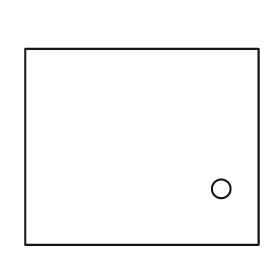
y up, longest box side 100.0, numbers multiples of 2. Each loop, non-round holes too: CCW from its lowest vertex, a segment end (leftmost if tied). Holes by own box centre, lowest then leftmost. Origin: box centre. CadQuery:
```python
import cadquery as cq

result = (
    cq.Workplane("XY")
    .moveTo(-50.0, -42.0)
    .lineTo(50.0, -42.0)
    .lineTo(50.0, 42.0)
    .lineTo(-50.0, 42.0)
    .close()
    .moveTo(34.0, -18.0)
    .circle(4.0)
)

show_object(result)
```